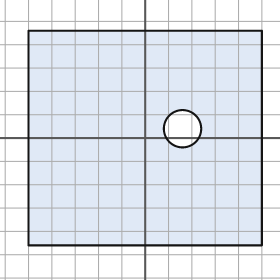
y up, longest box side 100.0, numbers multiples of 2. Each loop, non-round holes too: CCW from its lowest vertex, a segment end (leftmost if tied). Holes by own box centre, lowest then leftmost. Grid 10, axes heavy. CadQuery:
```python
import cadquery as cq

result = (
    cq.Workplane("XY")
    .moveTo(-50.0, -46.0)
    .lineTo(50.0, -46.0)
    .lineTo(50.0, 46.0)
    .lineTo(-50.0, 46.0)
    .close()
    .moveTo(16.0, 4.0)
    .circle(8.0)
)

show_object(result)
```